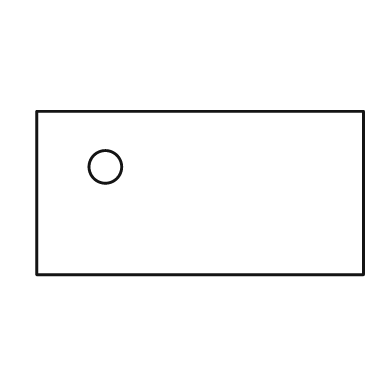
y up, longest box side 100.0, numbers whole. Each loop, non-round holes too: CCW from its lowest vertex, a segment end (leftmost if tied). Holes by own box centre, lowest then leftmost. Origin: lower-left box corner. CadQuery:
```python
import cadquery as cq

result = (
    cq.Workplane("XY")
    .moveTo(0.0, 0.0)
    .lineTo(100.0, 0.0)
    .lineTo(100.0, 50.0)
    .lineTo(0.0, 50.0)
    .close()
    .moveTo(21.0, 33.0)
    .circle(5.0)
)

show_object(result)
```